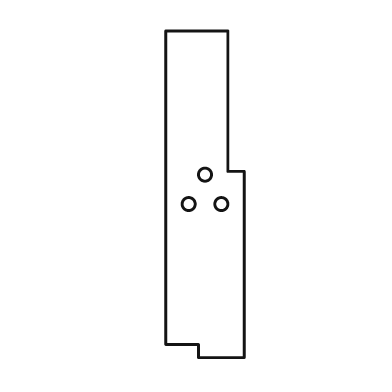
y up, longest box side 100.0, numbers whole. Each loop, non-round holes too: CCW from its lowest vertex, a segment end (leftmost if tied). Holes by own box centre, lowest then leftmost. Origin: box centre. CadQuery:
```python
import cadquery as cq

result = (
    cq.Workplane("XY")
    .moveTo(-2.0, -50.0)
    .lineTo(12.0, -50.0)
    .lineTo(12.0, 7.0)
    .lineTo(7.0, 7.0)
    .lineTo(7.0, 50.0)
    .lineTo(-12.0, 50.0)
    .lineTo(-12.0, -46.0)
    .lineTo(-2.0, -46.0)
    .close()
    .moveTo(-5.0, -3.0)
    .circle(2.0)
    .moveTo(5.0, -3.0)
    .circle(2.0)
    .moveTo(0.0, 6.0)
    .circle(2.0)
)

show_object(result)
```